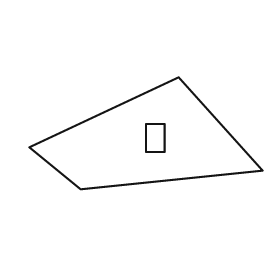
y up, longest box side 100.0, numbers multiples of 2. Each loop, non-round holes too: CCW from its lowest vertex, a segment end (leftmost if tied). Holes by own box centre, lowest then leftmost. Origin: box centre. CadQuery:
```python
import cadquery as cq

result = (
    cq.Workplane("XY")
    .moveTo(-28.0, -24.0)
    .lineTo(50.0, -16.0)
    .lineTo(14.0, 24.0)
    .lineTo(-50.0, -6.0)
    .close()
    .moveTo(0.0, -8.0)
    .lineTo(8.0, -8.0)
    .lineTo(8.0, 4.0)
    .lineTo(0.0, 4.0)
    .close()
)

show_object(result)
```